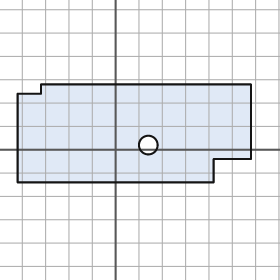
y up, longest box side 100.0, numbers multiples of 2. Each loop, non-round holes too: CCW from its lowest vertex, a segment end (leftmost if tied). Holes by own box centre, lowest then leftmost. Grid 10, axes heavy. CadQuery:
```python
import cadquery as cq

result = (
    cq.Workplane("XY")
    .moveTo(-42.0, -14.0)
    .lineTo(42.0, -14.0)
    .lineTo(42.0, -4.0)
    .lineTo(58.0, -4.0)
    .lineTo(58.0, 28.0)
    .lineTo(-32.0, 28.0)
    .lineTo(-32.0, 24.0)
    .lineTo(-42.0, 24.0)
    .close()
    .moveTo(14.0, 2.0)
    .circle(4.0)
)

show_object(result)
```